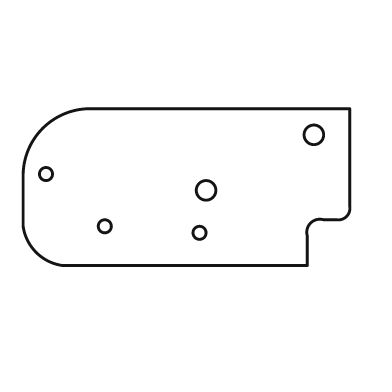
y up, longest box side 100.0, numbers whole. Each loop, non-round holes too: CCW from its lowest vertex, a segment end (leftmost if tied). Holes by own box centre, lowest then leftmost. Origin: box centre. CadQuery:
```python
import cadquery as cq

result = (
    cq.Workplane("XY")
    .moveTo(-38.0, -24.0)
    .lineTo(37.0, -24.0)
    .lineTo(37.0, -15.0)
    .threePointArc((38.0, -11.0), (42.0, -10.0))
    .lineTo(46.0, -10.0)
    .threePointArc((49.0, -9.0), (50.0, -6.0))
    .lineTo(50.0, 24.0)
    .lineTo(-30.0, 24.0)
    .threePointArc((-44.0, 18.0), (-50.0, 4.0))
    .lineTo(-50.0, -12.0)
    .threePointArc((-46.0, -20.0), (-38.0, -24.0))
    .close()
    .moveTo(4.0, -14.0)
    .circle(2.0)
    .moveTo(-25.0, -12.0)
    .circle(2.0)
    .moveTo(6.0, -1.0)
    .circle(3.0)
    .moveTo(-43.0, 4.0)
    .circle(2.0)
    .moveTo(39.0, 16.0)
    .circle(3.0)
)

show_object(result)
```